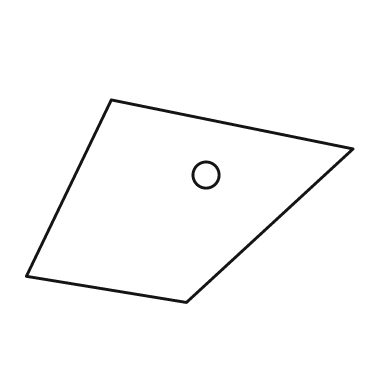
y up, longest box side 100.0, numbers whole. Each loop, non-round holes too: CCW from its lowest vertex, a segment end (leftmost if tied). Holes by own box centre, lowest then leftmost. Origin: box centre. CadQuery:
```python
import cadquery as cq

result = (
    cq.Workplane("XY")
    .moveTo(-1.0, -31.0)
    .lineTo(50.0, 16.0)
    .lineTo(-24.0, 31.0)
    .lineTo(-50.0, -23.0)
    .close()
    .moveTo(5.0, 8.0)
    .circle(4.0)
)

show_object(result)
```